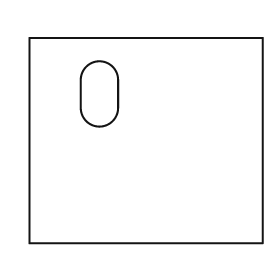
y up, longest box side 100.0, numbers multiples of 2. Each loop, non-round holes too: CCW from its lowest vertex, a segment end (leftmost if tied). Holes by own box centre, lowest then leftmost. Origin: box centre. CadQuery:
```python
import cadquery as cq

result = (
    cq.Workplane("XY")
    .moveTo(-50.0, -44.0)
    .lineTo(50.0, -44.0)
    .lineTo(50.0, 44.0)
    .lineTo(-50.0, 44.0)
    .close()
    .moveTo(-28.0, 14.0)
    .threePointArc((-20.0, 6.0), (-12.0, 14.0))
    .lineTo(-12.0, 26.0)
    .threePointArc((-20.0, 34.0), (-28.0, 26.0))
    .close()
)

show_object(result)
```